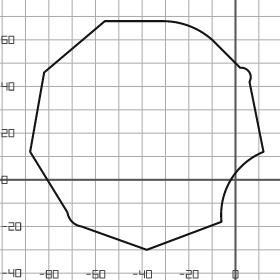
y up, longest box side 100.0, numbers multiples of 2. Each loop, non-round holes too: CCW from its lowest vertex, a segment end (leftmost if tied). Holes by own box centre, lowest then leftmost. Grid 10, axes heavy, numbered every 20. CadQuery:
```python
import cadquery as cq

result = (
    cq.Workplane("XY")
    .moveTo(-38.0, -30.0)
    .lineTo(-6.0, -18.0)
    .threePointArc((-2.0, 0.0), (12.0, 12.0))
    .lineTo(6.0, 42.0)
    .threePointArc((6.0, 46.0), (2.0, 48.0))
    .lineTo(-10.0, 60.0)
    .threePointArc((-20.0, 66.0), (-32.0, 68.0))
    .lineTo(-56.0, 68.0)
    .lineTo(-82.0, 46.0)
    .lineTo(-88.0, 12.0)
    .lineTo(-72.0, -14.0)
    .threePointArc((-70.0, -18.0), (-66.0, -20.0))
    .close()
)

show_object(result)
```